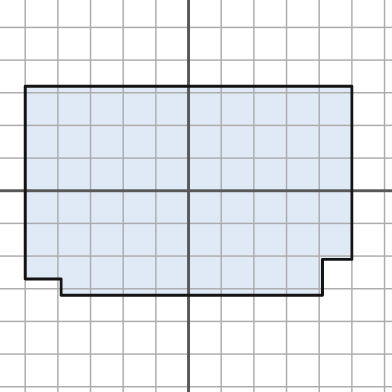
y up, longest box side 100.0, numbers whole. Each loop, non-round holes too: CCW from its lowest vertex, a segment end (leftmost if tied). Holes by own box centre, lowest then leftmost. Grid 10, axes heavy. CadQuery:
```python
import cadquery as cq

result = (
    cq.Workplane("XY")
    .moveTo(-39.0, -32.0)
    .lineTo(41.0, -32.0)
    .lineTo(41.0, -21.0)
    .lineTo(50.0, -21.0)
    .lineTo(50.0, 32.0)
    .lineTo(-50.0, 32.0)
    .lineTo(-50.0, -27.0)
    .lineTo(-39.0, -27.0)
    .close()
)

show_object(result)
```